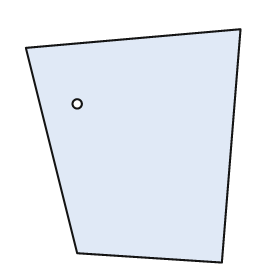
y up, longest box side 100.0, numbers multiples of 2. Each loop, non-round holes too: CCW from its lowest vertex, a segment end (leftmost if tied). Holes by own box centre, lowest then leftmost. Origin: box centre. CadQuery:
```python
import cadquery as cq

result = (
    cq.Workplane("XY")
    .moveTo(38.0, -50.0)
    .lineTo(46.0, 50.0)
    .lineTo(-46.0, 42.0)
    .lineTo(-24.0, -46.0)
    .close()
    .moveTo(-24.0, 18.0)
    .circle(2.0)
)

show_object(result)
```